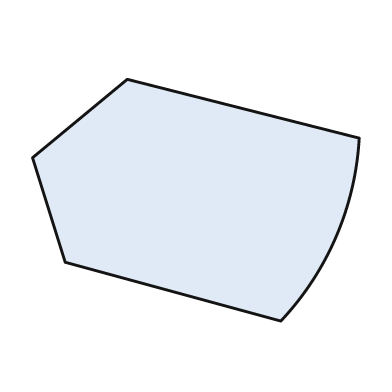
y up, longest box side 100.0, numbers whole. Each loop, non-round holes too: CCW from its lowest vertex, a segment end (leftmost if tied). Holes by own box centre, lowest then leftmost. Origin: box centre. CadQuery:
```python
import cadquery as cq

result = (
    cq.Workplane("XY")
    .moveTo(26.0, -37.0)
    .threePointArc((43.0, -11.0), (50.0, 19.0))
    .lineTo(-21.0, 37.0)
    .lineTo(-50.0, 13.0)
    .lineTo(-40.0, -19.0)
    .close()
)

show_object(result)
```